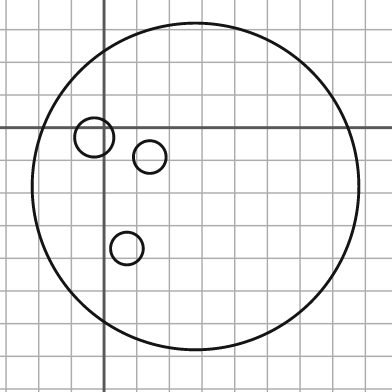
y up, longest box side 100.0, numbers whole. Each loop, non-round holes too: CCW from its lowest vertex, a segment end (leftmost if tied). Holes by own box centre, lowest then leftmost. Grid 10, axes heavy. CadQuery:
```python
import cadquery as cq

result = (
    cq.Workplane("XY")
    .moveTo(28.0, -18.0)
    .circle(50.0)
    .moveTo(7.0, -37.0)
    .circle(5.0)
    .moveTo(14.0, -9.0)
    .circle(5.0)
    .moveTo(-3.0, -3.0)
    .circle(6.0)
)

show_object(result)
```